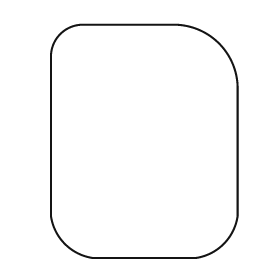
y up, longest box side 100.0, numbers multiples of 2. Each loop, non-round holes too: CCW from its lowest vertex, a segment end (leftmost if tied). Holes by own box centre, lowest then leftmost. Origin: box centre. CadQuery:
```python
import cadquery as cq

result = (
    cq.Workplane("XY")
    .moveTo(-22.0, -50.0)
    .lineTo(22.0, -50.0)
    .threePointArc((34.0, -44.0), (40.0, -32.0))
    .lineTo(40.0, 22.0)
    .threePointArc((32.0, 42.0), (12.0, 50.0))
    .lineTo(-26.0, 50.0)
    .threePointArc((-36.0, 46.0), (-40.0, 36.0))
    .lineTo(-40.0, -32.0)
    .threePointArc((-34.0, -44.0), (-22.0, -50.0))
    .close()
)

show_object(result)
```